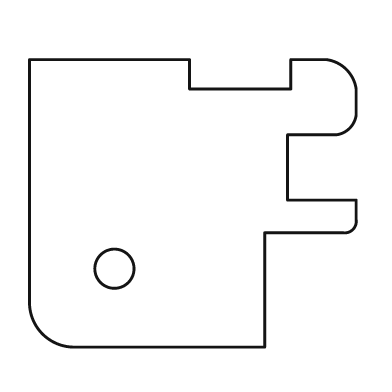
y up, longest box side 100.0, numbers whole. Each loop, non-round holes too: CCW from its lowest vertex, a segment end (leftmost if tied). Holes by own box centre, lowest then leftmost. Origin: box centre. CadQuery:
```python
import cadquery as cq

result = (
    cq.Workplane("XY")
    .moveTo(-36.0, -44.0)
    .lineTo(22.0, -44.0)
    .lineTo(22.0, -9.0)
    .lineTo(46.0, -9.0)
    .threePointArc((49.0, -8.0), (50.0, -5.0))
    .lineTo(50.0, 1.0)
    .lineTo(29.0, 1.0)
    .lineTo(29.0, 21.0)
    .lineTo(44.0, 21.0)
    .threePointArc((48.0, 23.0), (50.0, 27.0))
    .lineTo(50.0, 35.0)
    .threePointArc((47.0, 41.0), (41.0, 44.0))
    .lineTo(30.0, 44.0)
    .lineTo(30.0, 35.0)
    .lineTo(-1.0, 35.0)
    .lineTo(-1.0, 44.0)
    .lineTo(-50.0, 44.0)
    .lineTo(-50.0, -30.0)
    .threePointArc((-46.0, -40.0), (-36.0, -44.0))
    .close()
    .moveTo(-24.0, -20.0)
    .circle(6.0)
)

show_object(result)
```